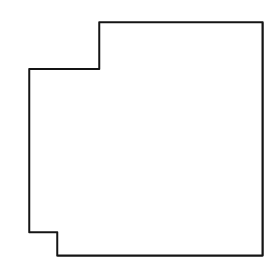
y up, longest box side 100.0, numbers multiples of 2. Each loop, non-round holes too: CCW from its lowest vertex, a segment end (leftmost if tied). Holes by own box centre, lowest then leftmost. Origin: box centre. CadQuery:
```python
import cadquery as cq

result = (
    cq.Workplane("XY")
    .moveTo(-38.0, -50.0)
    .lineTo(50.0, -50.0)
    .lineTo(50.0, 50.0)
    .lineTo(-20.0, 50.0)
    .lineTo(-20.0, 30.0)
    .lineTo(-50.0, 30.0)
    .lineTo(-50.0, -40.0)
    .lineTo(-38.0, -40.0)
    .close()
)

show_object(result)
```